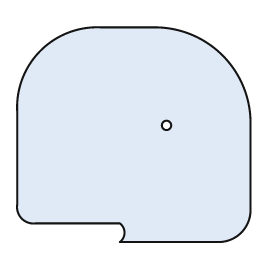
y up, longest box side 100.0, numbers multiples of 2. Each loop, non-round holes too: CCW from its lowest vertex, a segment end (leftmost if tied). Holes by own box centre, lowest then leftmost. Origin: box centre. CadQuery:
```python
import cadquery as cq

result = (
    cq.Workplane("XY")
    .moveTo(-6.0, -46.0)
    .lineTo(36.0, -46.0)
    .threePointArc((46.0, -42.0), (50.0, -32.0))
    .lineTo(50.0, 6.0)
    .threePointArc((38.0, 34.0), (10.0, 46.0))
    .lineTo(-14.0, 46.0)
    .threePointArc((-40.0, 36.0), (-50.0, 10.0))
    .lineTo(-50.0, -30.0)
    .threePointArc((-48.0, -36.0), (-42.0, -38.0))
    .lineTo(-6.0, -38.0)
    .threePointArc((-4.0, -42.0), (-6.0, -46.0))
    .close()
    .moveTo(14.0, 4.0)
    .circle(2.0)
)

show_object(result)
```